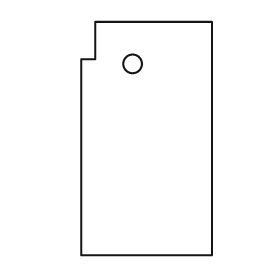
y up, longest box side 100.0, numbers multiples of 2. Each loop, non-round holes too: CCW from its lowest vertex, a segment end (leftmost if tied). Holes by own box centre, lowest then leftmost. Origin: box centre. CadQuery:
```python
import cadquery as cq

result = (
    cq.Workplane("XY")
    .moveTo(-28.0, -50.0)
    .lineTo(28.0, -50.0)
    .lineTo(28.0, 50.0)
    .lineTo(-22.0, 50.0)
    .lineTo(-22.0, 34.0)
    .lineTo(-28.0, 34.0)
    .close()
    .moveTo(-6.0, 32.0)
    .circle(4.0)
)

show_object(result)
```